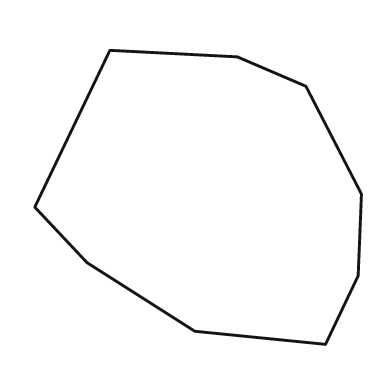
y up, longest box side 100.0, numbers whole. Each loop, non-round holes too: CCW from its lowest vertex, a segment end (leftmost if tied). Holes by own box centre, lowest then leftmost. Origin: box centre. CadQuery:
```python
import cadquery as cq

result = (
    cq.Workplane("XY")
    .moveTo(39.0, -45.0)
    .lineTo(49.0, -24.0)
    .lineTo(50.0, 1.0)
    .lineTo(33.0, 34.0)
    .lineTo(12.0, 43.0)
    .lineTo(-27.0, 45.0)
    .lineTo(-50.0, -3.0)
    .lineTo(-34.0, -20.0)
    .lineTo(-1.0, -41.0)
    .close()
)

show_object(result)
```